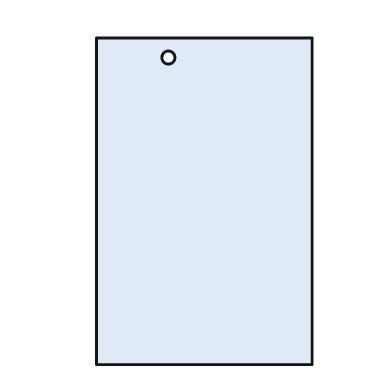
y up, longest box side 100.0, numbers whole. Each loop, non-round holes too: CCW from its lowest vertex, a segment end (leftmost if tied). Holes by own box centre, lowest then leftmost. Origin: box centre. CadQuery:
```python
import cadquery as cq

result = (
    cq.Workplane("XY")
    .moveTo(-33.0, -50.0)
    .lineTo(33.0, -50.0)
    .lineTo(33.0, 50.0)
    .lineTo(-33.0, 50.0)
    .close()
    .moveTo(-11.0, 44.0)
    .circle(2.0)
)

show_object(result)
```